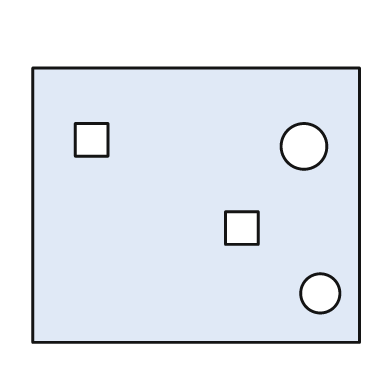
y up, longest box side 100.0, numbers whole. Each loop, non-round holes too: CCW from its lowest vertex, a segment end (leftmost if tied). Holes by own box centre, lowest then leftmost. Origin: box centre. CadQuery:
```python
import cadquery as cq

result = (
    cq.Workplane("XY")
    .moveTo(-50.0, -42.0)
    .lineTo(50.0, -42.0)
    .lineTo(50.0, 42.0)
    .lineTo(-50.0, 42.0)
    .close()
    .moveTo(38.0, -27.0)
    .circle(6.0)
    .moveTo(9.0, -12.0)
    .lineTo(19.0, -12.0)
    .lineTo(19.0, -2.0)
    .lineTo(9.0, -2.0)
    .close()
    .moveTo(33.0, 18.0)
    .circle(7.0)
    .moveTo(-37.0, 15.0)
    .lineTo(-27.0, 15.0)
    .lineTo(-27.0, 25.0)
    .lineTo(-37.0, 25.0)
    .close()
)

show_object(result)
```